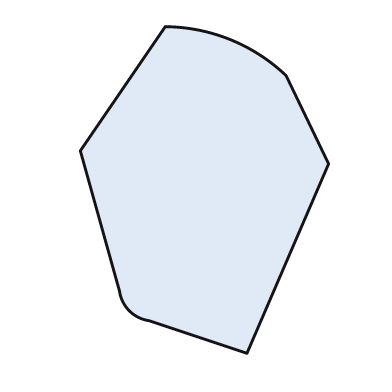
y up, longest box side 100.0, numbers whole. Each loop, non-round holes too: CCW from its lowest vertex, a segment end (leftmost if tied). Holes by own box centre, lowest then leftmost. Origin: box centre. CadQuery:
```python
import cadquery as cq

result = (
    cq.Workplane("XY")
    .moveTo(13.0, -50.0)
    .lineTo(38.0, 8.0)
    .lineTo(25.0, 35.0)
    .threePointArc((8.0, 46.0), (-12.0, 50.0))
    .lineTo(-38.0, 12.0)
    .lineTo(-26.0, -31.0)
    .threePointArc((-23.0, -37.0), (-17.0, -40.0))
    .close()
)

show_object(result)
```